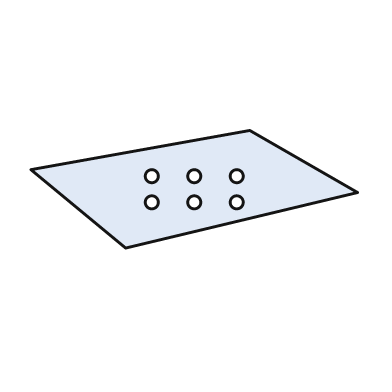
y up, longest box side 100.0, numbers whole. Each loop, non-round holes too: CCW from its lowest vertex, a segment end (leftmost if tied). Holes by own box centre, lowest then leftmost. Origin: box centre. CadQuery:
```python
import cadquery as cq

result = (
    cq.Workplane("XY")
    .moveTo(-21.0, -18.0)
    .lineTo(50.0, -1.0)
    .lineTo(17.0, 18.0)
    .lineTo(-50.0, 6.0)
    .close()
    .moveTo(-13.0, -4.0)
    .circle(2.0)
    .moveTo(0.0, -4.0)
    .circle(2.0)
    .moveTo(13.0, -4.0)
    .circle(2.0)
    .moveTo(-13.0, 4.0)
    .circle(2.0)
    .moveTo(0.0, 4.0)
    .circle(2.0)
    .moveTo(13.0, 4.0)
    .circle(2.0)
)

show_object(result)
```